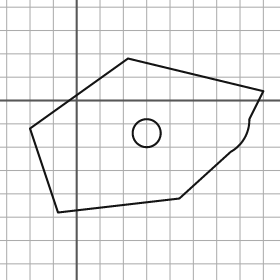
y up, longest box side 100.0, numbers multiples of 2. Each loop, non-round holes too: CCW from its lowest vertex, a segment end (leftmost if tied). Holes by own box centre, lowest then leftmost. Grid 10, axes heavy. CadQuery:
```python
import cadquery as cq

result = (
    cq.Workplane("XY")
    .moveTo(-8.0, -48.0)
    .lineTo(44.0, -42.0)
    .lineTo(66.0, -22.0)
    .threePointArc((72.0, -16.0), (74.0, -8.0))
    .lineTo(80.0, 4.0)
    .lineTo(22.0, 18.0)
    .lineTo(-20.0, -12.0)
    .close()
    .moveTo(30.0, -14.0)
    .circle(6.0)
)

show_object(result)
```